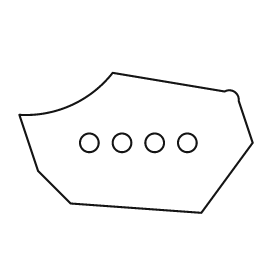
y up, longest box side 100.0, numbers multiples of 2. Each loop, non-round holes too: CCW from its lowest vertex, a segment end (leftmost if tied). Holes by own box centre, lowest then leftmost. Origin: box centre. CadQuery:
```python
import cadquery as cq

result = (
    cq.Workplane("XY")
    .moveTo(28.0, -30.0)
    .lineTo(50.0, 0.0)
    .lineTo(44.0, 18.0)
    .threePointArc((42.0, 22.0), (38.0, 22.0))
    .lineTo(-10.0, 30.0)
    .threePointArc((-28.0, 16.0), (-50.0, 12.0))
    .lineTo(-42.0, -12.0)
    .lineTo(-28.0, -26.0)
    .close()
    .moveTo(-20.0, 0.0)
    .circle(4.0)
    .moveTo(-6.0, 0.0)
    .circle(4.0)
    .moveTo(8.0, 0.0)
    .circle(4.0)
    .moveTo(22.0, 0.0)
    .circle(4.0)
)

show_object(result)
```